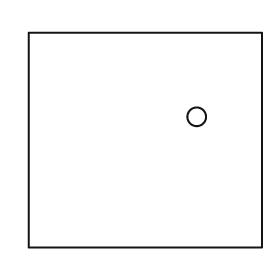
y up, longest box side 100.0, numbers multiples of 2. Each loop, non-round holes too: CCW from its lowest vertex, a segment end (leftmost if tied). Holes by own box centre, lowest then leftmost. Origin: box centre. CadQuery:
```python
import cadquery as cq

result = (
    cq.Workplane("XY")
    .moveTo(-50.0, -46.0)
    .lineTo(50.0, -46.0)
    .lineTo(50.0, 46.0)
    .lineTo(-50.0, 46.0)
    .close()
    .moveTo(22.0, 10.0)
    .circle(4.0)
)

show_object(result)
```